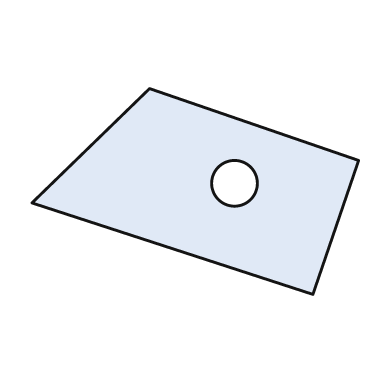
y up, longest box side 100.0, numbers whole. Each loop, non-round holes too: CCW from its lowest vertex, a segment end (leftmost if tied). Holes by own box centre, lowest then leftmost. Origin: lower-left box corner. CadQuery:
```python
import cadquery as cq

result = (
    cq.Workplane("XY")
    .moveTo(86.0, 0.0)
    .lineTo(100.0, 41.0)
    .lineTo(36.0, 63.0)
    .lineTo(0.0, 28.0)
    .close()
    .moveTo(62.0, 34.0)
    .circle(7.0)
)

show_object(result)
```